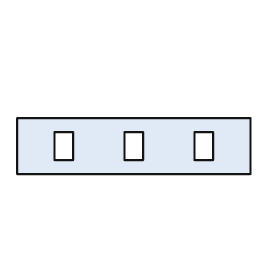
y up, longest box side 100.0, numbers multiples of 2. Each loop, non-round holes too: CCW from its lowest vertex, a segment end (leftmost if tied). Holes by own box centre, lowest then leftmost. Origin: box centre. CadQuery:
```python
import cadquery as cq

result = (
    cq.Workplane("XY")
    .moveTo(-50.0, -12.0)
    .lineTo(50.0, -12.0)
    .lineTo(50.0, 12.0)
    .lineTo(-50.0, 12.0)
    .close()
    .moveTo(-34.0, -6.0)
    .lineTo(-26.0, -6.0)
    .lineTo(-26.0, 6.0)
    .lineTo(-34.0, 6.0)
    .close()
    .moveTo(-4.0, -6.0)
    .lineTo(4.0, -6.0)
    .lineTo(4.0, 6.0)
    .lineTo(-4.0, 6.0)
    .close()
    .moveTo(26.0, -6.0)
    .lineTo(34.0, -6.0)
    .lineTo(34.0, 6.0)
    .lineTo(26.0, 6.0)
    .close()
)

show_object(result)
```